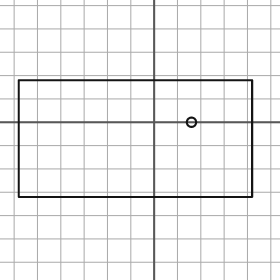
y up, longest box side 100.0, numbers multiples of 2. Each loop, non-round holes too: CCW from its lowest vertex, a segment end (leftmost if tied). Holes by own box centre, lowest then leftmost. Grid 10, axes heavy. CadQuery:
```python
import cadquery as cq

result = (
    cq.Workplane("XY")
    .moveTo(-58.0, -32.0)
    .lineTo(42.0, -32.0)
    .lineTo(42.0, 18.0)
    .lineTo(-58.0, 18.0)
    .close()
    .moveTo(16.0, 0.0)
    .circle(2.0)
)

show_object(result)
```